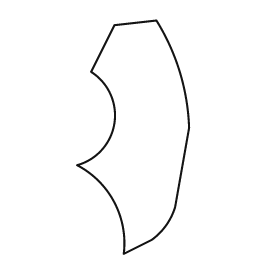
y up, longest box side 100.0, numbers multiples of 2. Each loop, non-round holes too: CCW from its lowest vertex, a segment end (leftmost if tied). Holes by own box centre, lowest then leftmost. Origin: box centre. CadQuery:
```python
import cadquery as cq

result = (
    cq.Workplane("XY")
    .moveTo(-4.0, -50.0)
    .lineTo(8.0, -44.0)
    .threePointArc((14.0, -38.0), (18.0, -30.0))
    .lineTo(24.0, 4.0)
    .threePointArc((20.0, 28.0), (10.0, 50.0))
    .lineTo(-8.0, 48.0)
    .lineTo(-18.0, 28.0)
    .threePointArc((-8.0, 6.0), (-24.0, -12.0))
    .threePointArc((-8.0, -28.0), (-4.0, -50.0))
    .close()
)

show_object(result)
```